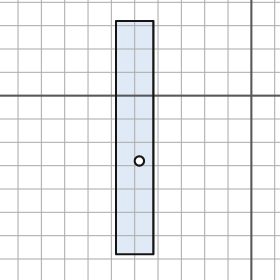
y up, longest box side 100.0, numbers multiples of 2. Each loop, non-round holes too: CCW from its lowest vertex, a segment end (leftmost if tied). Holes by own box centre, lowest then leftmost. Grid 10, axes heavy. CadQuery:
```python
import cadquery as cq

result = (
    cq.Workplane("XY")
    .moveTo(-58.0, -68.0)
    .lineTo(-42.0, -68.0)
    .lineTo(-42.0, 32.0)
    .lineTo(-58.0, 32.0)
    .close()
    .moveTo(-48.0, -28.0)
    .circle(2.0)
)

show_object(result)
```